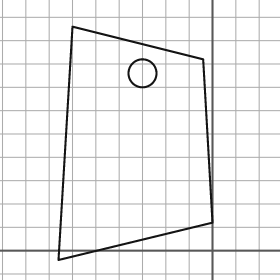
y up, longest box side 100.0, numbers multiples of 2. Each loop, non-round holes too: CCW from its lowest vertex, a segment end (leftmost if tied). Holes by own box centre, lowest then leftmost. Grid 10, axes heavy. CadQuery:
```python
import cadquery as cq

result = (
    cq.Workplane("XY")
    .moveTo(-66.0, -4.0)
    .lineTo(0.0, 12.0)
    .lineTo(-4.0, 82.0)
    .lineTo(-60.0, 96.0)
    .close()
    .moveTo(-30.0, 76.0)
    .circle(6.0)
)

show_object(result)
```